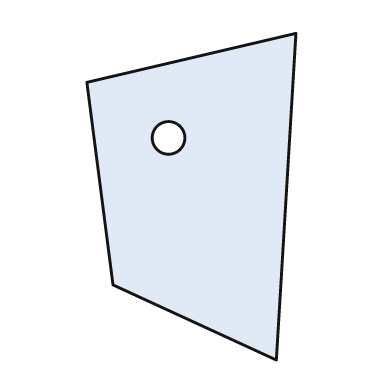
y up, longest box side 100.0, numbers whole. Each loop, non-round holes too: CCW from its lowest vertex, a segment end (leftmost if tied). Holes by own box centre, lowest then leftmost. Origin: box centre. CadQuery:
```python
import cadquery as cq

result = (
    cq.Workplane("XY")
    .moveTo(26.0, -50.0)
    .lineTo(32.0, 50.0)
    .lineTo(-32.0, 35.0)
    .lineTo(-24.0, -27.0)
    .close()
    .moveTo(-7.0, 18.0)
    .circle(5.0)
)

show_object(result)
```